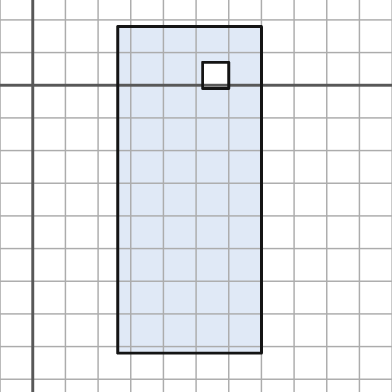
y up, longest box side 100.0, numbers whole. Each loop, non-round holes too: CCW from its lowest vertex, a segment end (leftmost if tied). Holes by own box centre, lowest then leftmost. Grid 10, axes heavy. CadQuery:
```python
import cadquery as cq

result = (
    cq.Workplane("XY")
    .moveTo(26.0, -82.0)
    .lineTo(70.0, -82.0)
    .lineTo(70.0, 18.0)
    .lineTo(26.0, 18.0)
    .close()
    .moveTo(52.0, -1.0)
    .lineTo(60.0, -1.0)
    .lineTo(60.0, 7.0)
    .lineTo(52.0, 7.0)
    .close()
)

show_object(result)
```